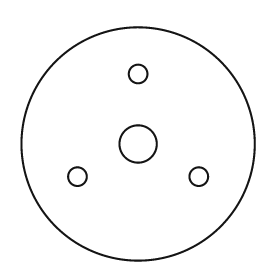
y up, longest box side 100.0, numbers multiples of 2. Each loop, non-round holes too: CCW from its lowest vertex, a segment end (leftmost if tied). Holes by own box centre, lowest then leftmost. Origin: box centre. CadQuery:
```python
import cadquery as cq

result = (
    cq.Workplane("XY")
    .moveTo(0.0, 0.0)
    .circle(50.0)
    .moveTo(-26.0, -14.0)
    .circle(4.0)
    .moveTo(26.0, -14.0)
    .circle(4.0)
    .moveTo(0.0, 0.0)
    .circle(8.0)
    .moveTo(0.0, 30.0)
    .circle(4.0)
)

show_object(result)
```